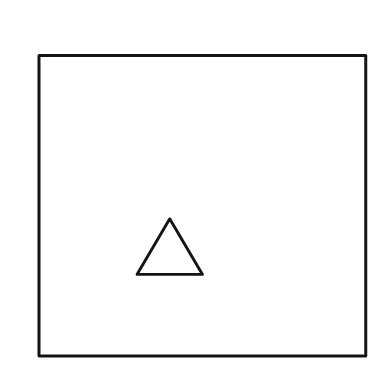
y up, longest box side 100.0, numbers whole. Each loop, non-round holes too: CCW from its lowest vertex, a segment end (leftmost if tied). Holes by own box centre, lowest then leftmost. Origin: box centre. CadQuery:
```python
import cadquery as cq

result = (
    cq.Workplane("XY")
    .moveTo(-50.0, -46.0)
    .lineTo(50.0, -46.0)
    .lineTo(50.0, 46.0)
    .lineTo(-50.0, 46.0)
    .close()
    .moveTo(-20.0, -21.0)
    .lineTo(0.0, -21.0)
    .lineTo(-10.0, -4.0)
    .close()
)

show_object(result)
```